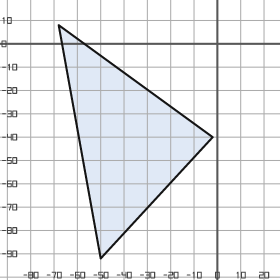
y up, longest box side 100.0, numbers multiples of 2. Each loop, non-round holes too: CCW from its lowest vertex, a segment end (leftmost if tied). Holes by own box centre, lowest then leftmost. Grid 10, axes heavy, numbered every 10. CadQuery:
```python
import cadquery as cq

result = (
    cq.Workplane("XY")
    .moveTo(-50.0, -92.0)
    .lineTo(-2.0, -40.0)
    .lineTo(-68.0, 8.0)
    .close()
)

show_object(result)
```